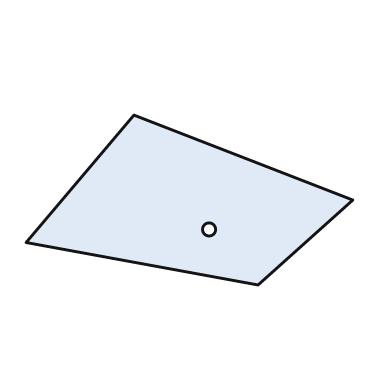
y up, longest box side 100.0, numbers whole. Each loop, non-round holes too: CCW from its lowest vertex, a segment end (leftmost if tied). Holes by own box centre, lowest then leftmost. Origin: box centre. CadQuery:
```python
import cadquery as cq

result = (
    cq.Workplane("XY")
    .moveTo(21.0, -26.0)
    .lineTo(50.0, 0.0)
    .lineTo(-17.0, 26.0)
    .lineTo(-50.0, -13.0)
    .close()
    .moveTo(6.0, -9.0)
    .circle(2.0)
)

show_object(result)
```